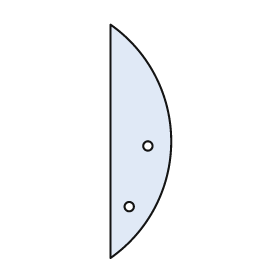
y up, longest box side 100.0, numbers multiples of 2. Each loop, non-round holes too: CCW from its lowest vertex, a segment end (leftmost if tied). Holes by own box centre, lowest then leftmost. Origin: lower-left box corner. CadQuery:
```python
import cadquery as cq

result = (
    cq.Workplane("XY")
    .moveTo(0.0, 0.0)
    .threePointArc((26.0, 50.0), (0.0, 100.0))
    .close()
    .moveTo(8.0, 22.0)
    .circle(2.0)
    .moveTo(16.0, 48.0)
    .circle(2.0)
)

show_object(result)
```